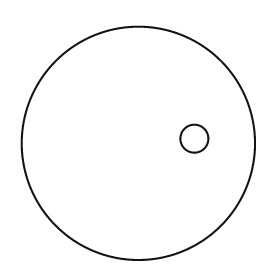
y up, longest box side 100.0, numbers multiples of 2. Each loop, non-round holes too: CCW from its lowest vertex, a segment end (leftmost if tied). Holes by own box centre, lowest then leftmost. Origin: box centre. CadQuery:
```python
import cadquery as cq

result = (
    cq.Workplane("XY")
    .moveTo(0.0, 0.0)
    .circle(50.0)
    .moveTo(24.0, 2.0)
    .circle(6.0)
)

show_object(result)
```